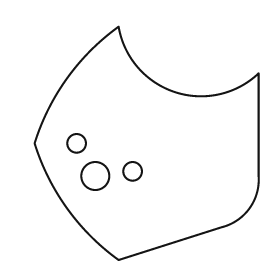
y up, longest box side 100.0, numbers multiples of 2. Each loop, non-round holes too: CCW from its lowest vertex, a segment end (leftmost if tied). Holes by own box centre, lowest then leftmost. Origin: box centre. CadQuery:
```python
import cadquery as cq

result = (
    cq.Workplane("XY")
    .moveTo(-12.0, -50.0)
    .lineTo(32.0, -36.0)
    .threePointArc((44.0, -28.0), (48.0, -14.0))
    .lineTo(48.0, 30.0)
    .threePointArc((12.0, 22.0), (-12.0, 50.0))
    .threePointArc((-34.0, 28.0), (-48.0, 0.0))
    .threePointArc((-34.0, -28.0), (-12.0, -50.0))
    .close()
    .moveTo(-22.0, -14.0)
    .circle(6.0)
    .moveTo(-6.0, -12.0)
    .circle(4.0)
    .moveTo(-30.0, 0.0)
    .circle(4.0)
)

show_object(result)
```